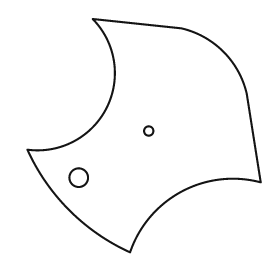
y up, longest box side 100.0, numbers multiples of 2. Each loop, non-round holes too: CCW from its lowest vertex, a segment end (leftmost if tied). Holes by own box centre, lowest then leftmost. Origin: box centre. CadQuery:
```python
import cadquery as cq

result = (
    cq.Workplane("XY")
    .moveTo(-6.0, -50.0)
    .threePointArc((16.0, -24.0), (50.0, -20.0))
    .lineTo(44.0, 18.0)
    .threePointArc((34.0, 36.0), (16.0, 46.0))
    .lineTo(-22.0, 50.0)
    .threePointArc((-16.0, 12.0), (-50.0, -6.0))
    .threePointArc((-32.0, -32.0), (-6.0, -50.0))
    .close()
    .moveTo(-28.0, -18.0)
    .circle(4.0)
    .moveTo(2.0, 2.0)
    .circle(2.0)
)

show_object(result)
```